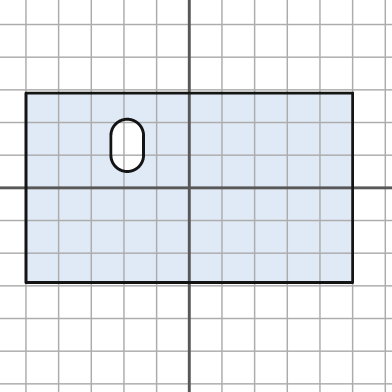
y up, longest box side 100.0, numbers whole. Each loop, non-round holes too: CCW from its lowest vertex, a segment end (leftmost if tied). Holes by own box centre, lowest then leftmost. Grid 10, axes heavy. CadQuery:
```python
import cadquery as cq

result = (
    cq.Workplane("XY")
    .moveTo(-50.0, -29.0)
    .lineTo(50.0, -29.0)
    .lineTo(50.0, 29.0)
    .lineTo(-50.0, 29.0)
    .close()
    .moveTo(-24.0, 10.0)
    .threePointArc((-19.0, 5.0), (-14.0, 10.0))
    .lineTo(-14.0, 16.0)
    .threePointArc((-19.0, 21.0), (-24.0, 16.0))
    .close()
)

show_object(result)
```